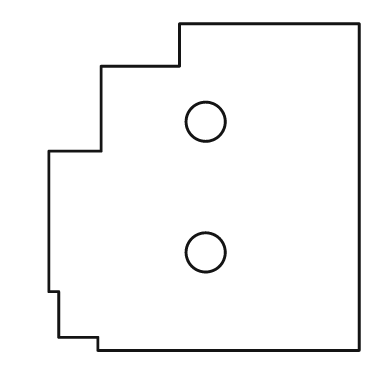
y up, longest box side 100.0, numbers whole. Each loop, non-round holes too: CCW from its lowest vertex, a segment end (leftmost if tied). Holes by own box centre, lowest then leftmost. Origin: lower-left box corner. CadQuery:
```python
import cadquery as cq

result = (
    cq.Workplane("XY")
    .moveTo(15.0, 0.0)
    .lineTo(95.0, 0.0)
    .lineTo(95.0, 100.0)
    .lineTo(40.0, 100.0)
    .lineTo(40.0, 87.0)
    .lineTo(16.0, 87.0)
    .lineTo(16.0, 61.0)
    .lineTo(0.0, 61.0)
    .lineTo(0.0, 18.0)
    .lineTo(3.0, 18.0)
    .lineTo(3.0, 4.0)
    .lineTo(15.0, 4.0)
    .close()
    .moveTo(48.0, 30.0)
    .circle(6.0)
    .moveTo(48.0, 70.0)
    .circle(6.0)
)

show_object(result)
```